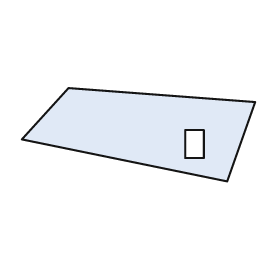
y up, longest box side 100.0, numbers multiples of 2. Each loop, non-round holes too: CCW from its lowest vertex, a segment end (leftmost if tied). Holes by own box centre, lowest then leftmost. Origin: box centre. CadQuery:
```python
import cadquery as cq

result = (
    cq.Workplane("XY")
    .moveTo(38.0, -20.0)
    .lineTo(50.0, 14.0)
    .lineTo(-30.0, 20.0)
    .lineTo(-50.0, -2.0)
    .close()
    .moveTo(20.0, -10.0)
    .lineTo(28.0, -10.0)
    .lineTo(28.0, 2.0)
    .lineTo(20.0, 2.0)
    .close()
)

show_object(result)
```